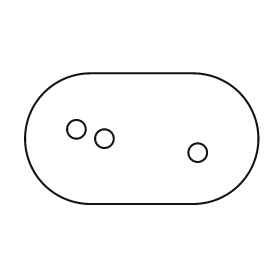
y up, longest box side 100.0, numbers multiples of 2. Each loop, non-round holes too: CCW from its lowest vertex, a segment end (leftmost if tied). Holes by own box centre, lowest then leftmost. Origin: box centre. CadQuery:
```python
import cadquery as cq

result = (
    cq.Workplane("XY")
    .moveTo(-22.0, -28.0)
    .lineTo(22.0, -28.0)
    .threePointArc((50.0, 0.0), (22.0, 28.0))
    .lineTo(-22.0, 28.0)
    .threePointArc((-50.0, 0.0), (-22.0, -28.0))
    .close()
    .moveTo(24.0, -6.0)
    .circle(4.0)
    .moveTo(-16.0, 0.0)
    .circle(4.0)
    .moveTo(-28.0, 4.0)
    .circle(4.0)
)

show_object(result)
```